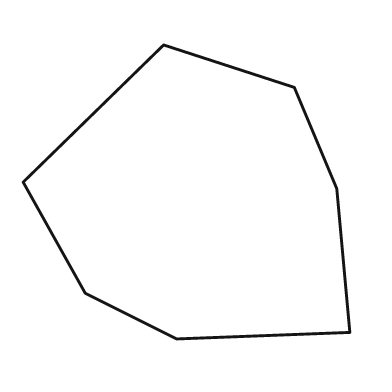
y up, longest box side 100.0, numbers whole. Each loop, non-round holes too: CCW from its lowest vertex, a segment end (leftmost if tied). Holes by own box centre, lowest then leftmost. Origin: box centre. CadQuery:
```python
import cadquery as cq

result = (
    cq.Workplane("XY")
    .moveTo(-3.0, -45.0)
    .lineTo(50.0, -43.0)
    .lineTo(46.0, 1.0)
    .lineTo(33.0, 32.0)
    .lineTo(-7.0, 45.0)
    .lineTo(-50.0, 3.0)
    .lineTo(-31.0, -31.0)
    .close()
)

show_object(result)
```